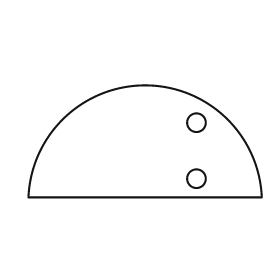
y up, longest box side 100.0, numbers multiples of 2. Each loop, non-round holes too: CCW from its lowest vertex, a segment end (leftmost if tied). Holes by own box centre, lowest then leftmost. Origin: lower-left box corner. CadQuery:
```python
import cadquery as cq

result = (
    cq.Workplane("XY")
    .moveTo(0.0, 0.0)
    .lineTo(100.0, 0.0)
    .threePointArc((50.0, 48.0), (0.0, 0.0))
    .close()
    .moveTo(72.0, 8.0)
    .circle(4.0)
    .moveTo(72.0, 32.0)
    .circle(4.0)
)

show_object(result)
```